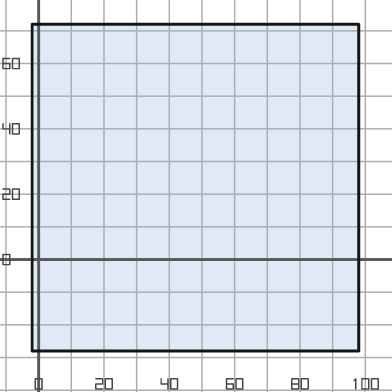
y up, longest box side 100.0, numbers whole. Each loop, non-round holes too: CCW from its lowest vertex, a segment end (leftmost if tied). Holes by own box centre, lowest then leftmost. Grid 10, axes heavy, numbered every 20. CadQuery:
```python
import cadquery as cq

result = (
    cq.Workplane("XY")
    .moveTo(-2.0, -28.0)
    .lineTo(98.0, -28.0)
    .lineTo(98.0, 72.0)
    .lineTo(-2.0, 72.0)
    .close()
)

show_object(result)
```